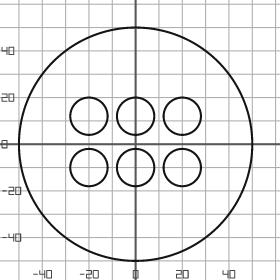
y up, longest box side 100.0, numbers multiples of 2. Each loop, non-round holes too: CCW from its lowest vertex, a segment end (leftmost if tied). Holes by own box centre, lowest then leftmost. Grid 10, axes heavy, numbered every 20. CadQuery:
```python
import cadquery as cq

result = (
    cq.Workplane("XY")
    .moveTo(0.0, 0.0)
    .circle(50.0)
    .moveTo(-20.0, -10.0)
    .circle(8.0)
    .moveTo(0.0, -10.0)
    .circle(8.0)
    .moveTo(20.0, -10.0)
    .circle(8.0)
    .moveTo(-20.0, 12.0)
    .circle(8.0)
    .moveTo(0.0, 12.0)
    .circle(8.0)
    .moveTo(20.0, 12.0)
    .circle(8.0)
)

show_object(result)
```